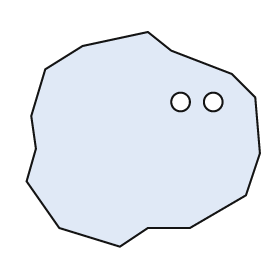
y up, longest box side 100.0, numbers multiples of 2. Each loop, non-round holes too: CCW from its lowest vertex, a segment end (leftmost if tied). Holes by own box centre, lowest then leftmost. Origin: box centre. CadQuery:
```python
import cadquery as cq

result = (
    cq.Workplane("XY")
    .moveTo(-10.0, -46.0)
    .lineTo(2.0, -38.0)
    .lineTo(20.0, -38.0)
    .lineTo(44.0, -24.0)
    .lineTo(50.0, -6.0)
    .lineTo(48.0, 18.0)
    .lineTo(38.0, 28.0)
    .lineTo(12.0, 38.0)
    .lineTo(2.0, 46.0)
    .lineTo(-26.0, 40.0)
    .lineTo(-42.0, 30.0)
    .lineTo(-48.0, 10.0)
    .lineTo(-46.0, -4.0)
    .lineTo(-50.0, -18.0)
    .lineTo(-36.0, -38.0)
    .close()
    .moveTo(16.0, 16.0)
    .circle(4.0)
    .moveTo(30.0, 16.0)
    .circle(4.0)
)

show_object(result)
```